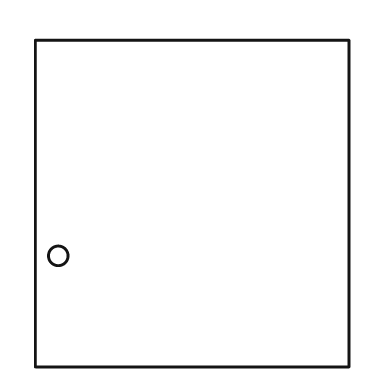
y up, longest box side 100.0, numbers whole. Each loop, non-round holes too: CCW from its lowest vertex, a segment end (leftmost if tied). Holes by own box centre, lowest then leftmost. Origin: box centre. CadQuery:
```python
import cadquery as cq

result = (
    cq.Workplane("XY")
    .moveTo(-48.0, -50.0)
    .lineTo(48.0, -50.0)
    .lineTo(48.0, 50.0)
    .lineTo(-48.0, 50.0)
    .close()
    .moveTo(-41.0, -16.0)
    .circle(3.0)
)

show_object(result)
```